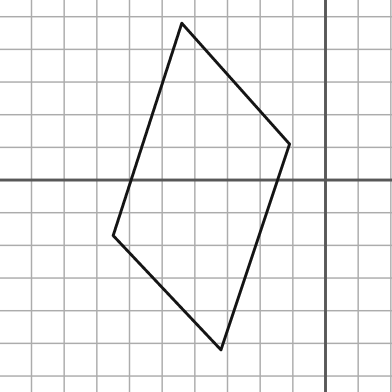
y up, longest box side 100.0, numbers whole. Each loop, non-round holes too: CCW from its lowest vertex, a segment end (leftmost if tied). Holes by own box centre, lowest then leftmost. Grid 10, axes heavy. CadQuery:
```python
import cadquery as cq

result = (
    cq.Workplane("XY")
    .moveTo(-32.0, -52.0)
    .lineTo(-11.0, 11.0)
    .lineTo(-44.0, 48.0)
    .lineTo(-65.0, -17.0)
    .close()
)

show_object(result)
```